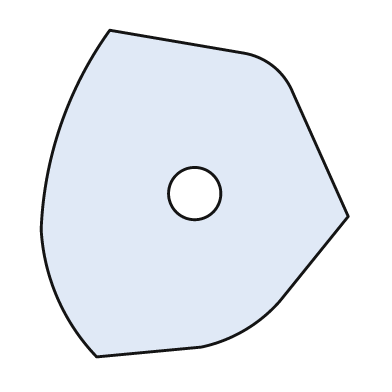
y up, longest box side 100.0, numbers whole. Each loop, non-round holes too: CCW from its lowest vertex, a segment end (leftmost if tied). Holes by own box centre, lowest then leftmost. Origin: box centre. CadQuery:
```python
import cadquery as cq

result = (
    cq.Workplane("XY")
    .moveTo(-30.0, -50.0)
    .lineTo(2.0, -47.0)
    .threePointArc((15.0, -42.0), (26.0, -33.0))
    .lineTo(47.0, -7.0)
    .lineTo(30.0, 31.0)
    .threePointArc((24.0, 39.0), (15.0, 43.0))
    .lineTo(-26.0, 50.0)
    .threePointArc((-41.0, 21.0), (-47.0, -11.0))
    .threePointArc((-42.0, -32.0), (-30.0, -50.0))
    .close()
    .moveTo(0.0, 0.0)
    .circle(8.0)
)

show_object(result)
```